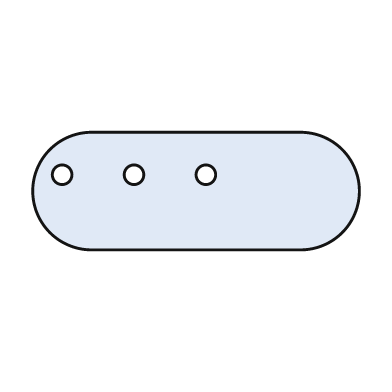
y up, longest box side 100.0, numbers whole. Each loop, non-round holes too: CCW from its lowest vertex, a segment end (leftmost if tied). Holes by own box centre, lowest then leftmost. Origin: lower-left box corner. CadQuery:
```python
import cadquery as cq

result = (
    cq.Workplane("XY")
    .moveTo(18.0, 0.0)
    .lineTo(82.0, 0.0)
    .threePointArc((100.0, 18.0), (82.0, 36.0))
    .lineTo(18.0, 36.0)
    .threePointArc((0.0, 18.0), (18.0, 0.0))
    .close()
    .moveTo(9.0, 23.0)
    .circle(3.0)
    .moveTo(31.0, 23.0)
    .circle(3.0)
    .moveTo(53.0, 23.0)
    .circle(3.0)
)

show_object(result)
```